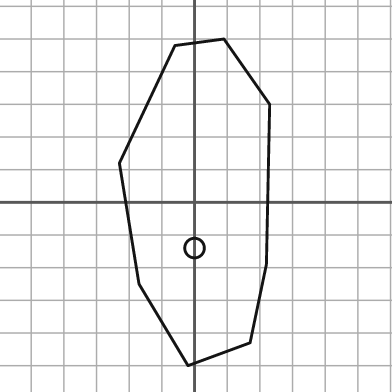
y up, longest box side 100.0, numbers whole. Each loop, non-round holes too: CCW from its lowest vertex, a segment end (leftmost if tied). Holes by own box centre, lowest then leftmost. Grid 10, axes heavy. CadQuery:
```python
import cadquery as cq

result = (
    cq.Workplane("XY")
    .moveTo(-2.0, -50.0)
    .lineTo(17.0, -43.0)
    .lineTo(22.0, -19.0)
    .lineTo(23.0, 30.0)
    .lineTo(9.0, 50.0)
    .lineTo(-6.0, 48.0)
    .lineTo(-23.0, 12.0)
    .lineTo(-17.0, -25.0)
    .close()
    .moveTo(0.0, -14.0)
    .circle(3.0)
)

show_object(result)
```